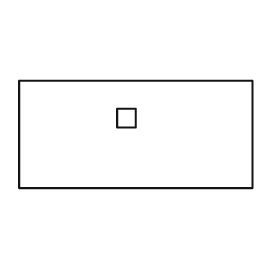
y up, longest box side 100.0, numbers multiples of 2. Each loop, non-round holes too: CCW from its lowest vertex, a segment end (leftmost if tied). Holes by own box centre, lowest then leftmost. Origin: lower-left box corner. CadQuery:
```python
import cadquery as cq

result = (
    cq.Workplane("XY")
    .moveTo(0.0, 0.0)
    .lineTo(100.0, 0.0)
    .lineTo(100.0, 46.0)
    .lineTo(0.0, 46.0)
    .close()
    .moveTo(42.0, 26.0)
    .lineTo(50.0, 26.0)
    .lineTo(50.0, 34.0)
    .lineTo(42.0, 34.0)
    .close()
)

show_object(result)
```